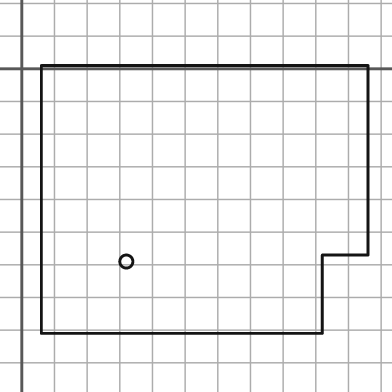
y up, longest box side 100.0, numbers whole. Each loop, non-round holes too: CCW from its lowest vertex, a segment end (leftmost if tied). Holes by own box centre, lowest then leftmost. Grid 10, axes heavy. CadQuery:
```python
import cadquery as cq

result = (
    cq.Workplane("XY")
    .moveTo(6.0, -81.0)
    .lineTo(92.0, -81.0)
    .lineTo(92.0, -57.0)
    .lineTo(106.0, -57.0)
    .lineTo(106.0, 1.0)
    .lineTo(6.0, 1.0)
    .close()
    .moveTo(32.0, -59.0)
    .circle(2.0)
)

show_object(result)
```